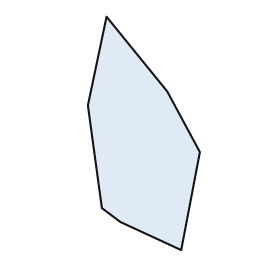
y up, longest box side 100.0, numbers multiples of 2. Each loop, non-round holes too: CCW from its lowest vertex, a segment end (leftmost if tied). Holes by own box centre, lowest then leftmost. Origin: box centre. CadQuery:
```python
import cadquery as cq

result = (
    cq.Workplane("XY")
    .moveTo(16.0, -50.0)
    .lineTo(24.0, -8.0)
    .lineTo(10.0, 18.0)
    .lineTo(-16.0, 50.0)
    .lineTo(-24.0, 12.0)
    .lineTo(-18.0, -32.0)
    .lineTo(-10.0, -38.0)
    .close()
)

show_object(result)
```